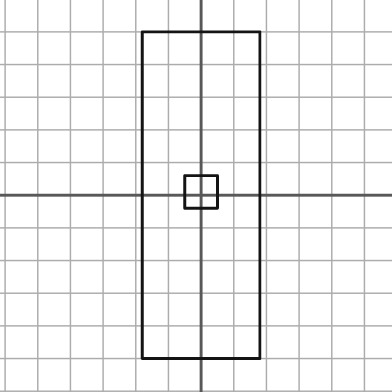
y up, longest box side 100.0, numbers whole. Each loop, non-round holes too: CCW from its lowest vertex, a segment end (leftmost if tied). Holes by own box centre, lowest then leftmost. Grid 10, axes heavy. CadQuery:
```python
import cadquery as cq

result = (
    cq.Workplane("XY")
    .moveTo(-18.0, -50.0)
    .lineTo(18.0, -50.0)
    .lineTo(18.0, 50.0)
    .lineTo(-18.0, 50.0)
    .close()
    .moveTo(-5.0, -4.0)
    .lineTo(5.0, -4.0)
    .lineTo(5.0, 6.0)
    .lineTo(-5.0, 6.0)
    .close()
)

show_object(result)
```